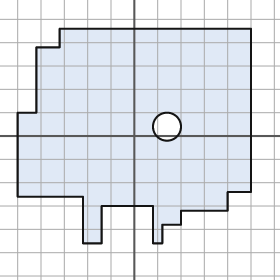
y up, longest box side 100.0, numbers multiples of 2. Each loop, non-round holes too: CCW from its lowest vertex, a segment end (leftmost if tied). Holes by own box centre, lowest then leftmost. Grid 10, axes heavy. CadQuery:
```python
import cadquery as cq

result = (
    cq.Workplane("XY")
    .moveTo(-22.0, -46.0)
    .lineTo(-14.0, -46.0)
    .lineTo(-14.0, -30.0)
    .lineTo(8.0, -30.0)
    .lineTo(8.0, -46.0)
    .lineTo(12.0, -46.0)
    .lineTo(12.0, -38.0)
    .lineTo(20.0, -38.0)
    .lineTo(20.0, -32.0)
    .lineTo(40.0, -32.0)
    .lineTo(40.0, -24.0)
    .lineTo(50.0, -24.0)
    .lineTo(50.0, 46.0)
    .lineTo(-32.0, 46.0)
    .lineTo(-32.0, 38.0)
    .lineTo(-42.0, 38.0)
    .lineTo(-42.0, 10.0)
    .lineTo(-50.0, 10.0)
    .lineTo(-50.0, -26.0)
    .lineTo(-22.0, -26.0)
    .close()
    .moveTo(14.0, 4.0)
    .circle(6.0)
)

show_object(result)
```